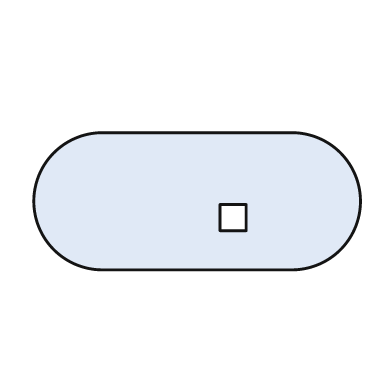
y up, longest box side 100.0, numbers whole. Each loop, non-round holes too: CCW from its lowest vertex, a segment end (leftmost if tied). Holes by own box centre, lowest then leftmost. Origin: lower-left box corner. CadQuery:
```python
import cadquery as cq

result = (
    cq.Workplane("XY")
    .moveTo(21.0, 0.0)
    .lineTo(79.0, 0.0)
    .threePointArc((100.0, 21.0), (79.0, 42.0))
    .lineTo(21.0, 42.0)
    .threePointArc((0.0, 21.0), (21.0, 0.0))
    .close()
    .moveTo(57.0, 12.0)
    .lineTo(65.0, 12.0)
    .lineTo(65.0, 20.0)
    .lineTo(57.0, 20.0)
    .close()
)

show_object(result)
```